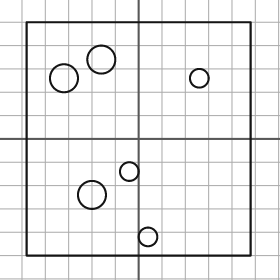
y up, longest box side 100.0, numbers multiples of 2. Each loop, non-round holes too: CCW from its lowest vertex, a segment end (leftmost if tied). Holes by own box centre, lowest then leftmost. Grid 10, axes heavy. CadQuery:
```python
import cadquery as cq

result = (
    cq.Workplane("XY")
    .moveTo(-48.0, -50.0)
    .lineTo(48.0, -50.0)
    .lineTo(48.0, 50.0)
    .lineTo(-48.0, 50.0)
    .close()
    .moveTo(4.0, -42.0)
    .circle(4.0)
    .moveTo(-20.0, -24.0)
    .circle(6.0)
    .moveTo(-4.0, -14.0)
    .circle(4.0)
    .moveTo(-32.0, 26.0)
    .circle(6.0)
    .moveTo(26.0, 26.0)
    .circle(4.0)
    .moveTo(-16.0, 34.0)
    .circle(6.0)
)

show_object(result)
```